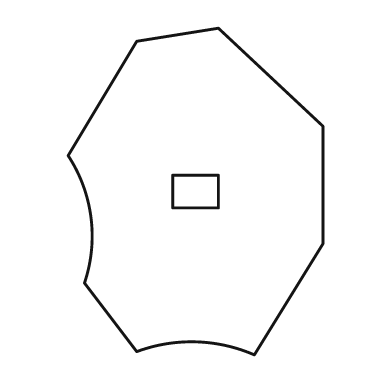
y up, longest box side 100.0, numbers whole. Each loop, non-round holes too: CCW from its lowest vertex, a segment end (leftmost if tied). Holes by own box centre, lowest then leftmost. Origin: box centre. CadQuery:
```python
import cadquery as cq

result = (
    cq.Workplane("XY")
    .moveTo(18.0, -50.0)
    .lineTo(39.0, -16.0)
    .lineTo(39.0, 20.0)
    .lineTo(7.0, 50.0)
    .lineTo(-18.0, 46.0)
    .lineTo(-39.0, 11.0)
    .threePointArc((-32.0, -8.0), (-34.0, -28.0))
    .lineTo(-18.0, -49.0)
    .threePointArc((0.0, -46.0), (18.0, -50.0))
    .close()
    .moveTo(-7.0, -5.0)
    .lineTo(7.0, -5.0)
    .lineTo(7.0, 5.0)
    .lineTo(-7.0, 5.0)
    .close()
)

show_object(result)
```